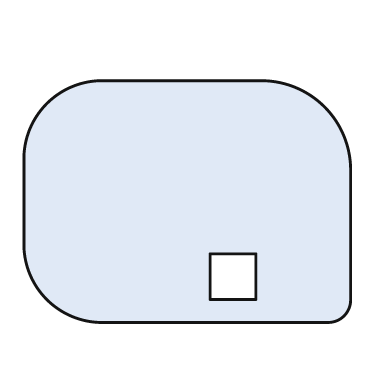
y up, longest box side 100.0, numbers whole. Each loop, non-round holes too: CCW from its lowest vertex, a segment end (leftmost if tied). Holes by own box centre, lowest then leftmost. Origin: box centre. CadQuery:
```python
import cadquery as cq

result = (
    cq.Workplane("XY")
    .moveTo(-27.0, -37.0)
    .lineTo(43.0, -37.0)
    .threePointArc((48.0, -35.0), (50.0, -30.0))
    .lineTo(50.0, 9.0)
    .threePointArc((42.0, 29.0), (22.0, 37.0))
    .lineTo(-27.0, 37.0)
    .threePointArc((-43.0, 30.0), (-50.0, 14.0))
    .lineTo(-50.0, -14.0)
    .threePointArc((-43.0, -30.0), (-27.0, -37.0))
    .close()
    .moveTo(7.0, -30.0)
    .lineTo(21.0, -30.0)
    .lineTo(21.0, -16.0)
    .lineTo(7.0, -16.0)
    .close()
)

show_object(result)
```